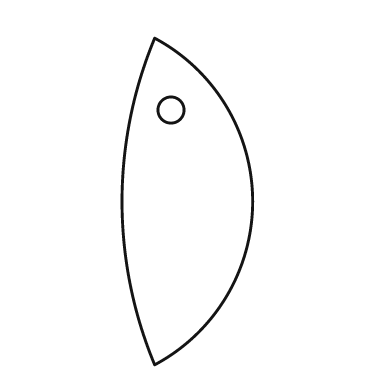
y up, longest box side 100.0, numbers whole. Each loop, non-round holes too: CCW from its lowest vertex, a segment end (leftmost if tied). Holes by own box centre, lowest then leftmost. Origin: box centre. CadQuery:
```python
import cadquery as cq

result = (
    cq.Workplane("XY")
    .moveTo(-10.0, -50.0)
    .threePointArc((20.0, 0.0), (-10.0, 50.0))
    .threePointArc((-20.0, 0.0), (-10.0, -50.0))
    .close()
    .moveTo(-5.0, 28.0)
    .circle(4.0)
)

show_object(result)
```